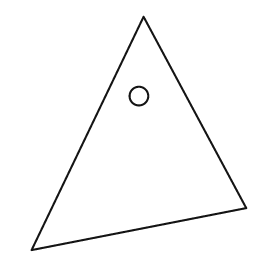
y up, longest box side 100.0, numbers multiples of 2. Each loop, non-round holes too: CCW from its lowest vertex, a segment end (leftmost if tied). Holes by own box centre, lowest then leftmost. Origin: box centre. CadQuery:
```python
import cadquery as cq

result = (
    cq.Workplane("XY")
    .moveTo(-46.0, -50.0)
    .lineTo(46.0, -32.0)
    .lineTo(2.0, 50.0)
    .close()
    .moveTo(0.0, 16.0)
    .circle(4.0)
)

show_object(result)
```